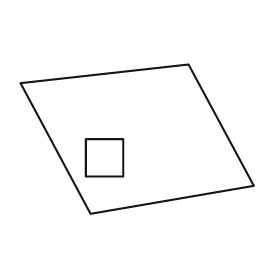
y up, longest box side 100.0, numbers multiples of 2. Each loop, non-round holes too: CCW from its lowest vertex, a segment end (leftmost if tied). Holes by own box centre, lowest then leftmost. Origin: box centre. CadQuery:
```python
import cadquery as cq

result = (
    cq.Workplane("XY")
    .moveTo(-20.0, -32.0)
    .lineTo(50.0, -20.0)
    .lineTo(22.0, 32.0)
    .lineTo(-50.0, 24.0)
    .close()
    .moveTo(-22.0, -16.0)
    .lineTo(-6.0, -16.0)
    .lineTo(-6.0, 0.0)
    .lineTo(-22.0, 0.0)
    .close()
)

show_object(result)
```